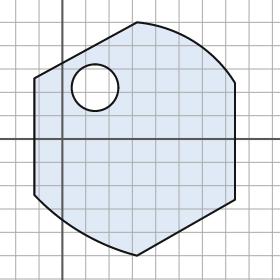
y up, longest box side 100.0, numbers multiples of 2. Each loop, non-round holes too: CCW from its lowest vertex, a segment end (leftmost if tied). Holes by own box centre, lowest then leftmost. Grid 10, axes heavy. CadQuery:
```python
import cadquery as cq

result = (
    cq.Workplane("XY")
    .moveTo(32.0, -50.0)
    .lineTo(74.0, -26.0)
    .lineTo(74.0, 24.0)
    .threePointArc((56.0, 42.0), (32.0, 50.0))
    .lineTo(-12.0, 26.0)
    .lineTo(-12.0, -24.0)
    .threePointArc((8.0, -40.0), (32.0, -50.0))
    .close()
    .moveTo(14.0, 22.0)
    .circle(10.0)
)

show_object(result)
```